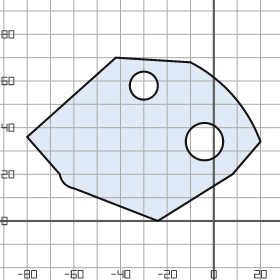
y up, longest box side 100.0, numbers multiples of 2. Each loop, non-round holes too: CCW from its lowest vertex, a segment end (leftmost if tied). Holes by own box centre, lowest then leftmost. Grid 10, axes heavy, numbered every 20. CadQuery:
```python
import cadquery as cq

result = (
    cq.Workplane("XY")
    .moveTo(-24.0, 0.0)
    .lineTo(8.0, 20.0)
    .lineTo(20.0, 34.0)
    .threePointArc((8.0, 54.0), (-10.0, 68.0))
    .lineTo(-42.0, 70.0)
    .lineTo(-80.0, 36.0)
    .lineTo(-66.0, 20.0)
    .threePointArc((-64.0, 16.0), (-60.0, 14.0))
    .close()
    .moveTo(-4.0, 34.0)
    .circle(8.0)
    .moveTo(-30.0, 58.0)
    .circle(6.0)
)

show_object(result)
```